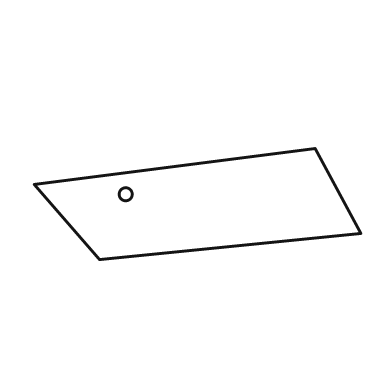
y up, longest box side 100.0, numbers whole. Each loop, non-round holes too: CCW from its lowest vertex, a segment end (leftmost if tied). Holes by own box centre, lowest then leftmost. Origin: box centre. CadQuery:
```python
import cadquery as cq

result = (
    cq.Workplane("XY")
    .moveTo(-30.0, -17.0)
    .lineTo(50.0, -9.0)
    .lineTo(36.0, 17.0)
    .lineTo(-50.0, 6.0)
    .close()
    .moveTo(-22.0, 3.0)
    .circle(2.0)
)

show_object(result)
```